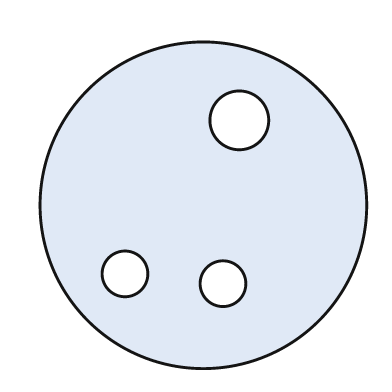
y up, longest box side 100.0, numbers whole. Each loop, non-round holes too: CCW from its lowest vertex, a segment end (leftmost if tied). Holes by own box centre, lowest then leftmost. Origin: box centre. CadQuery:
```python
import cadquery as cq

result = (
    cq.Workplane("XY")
    .moveTo(0.0, 0.0)
    .circle(50.0)
    .moveTo(6.0, -24.0)
    .circle(7.0)
    .moveTo(-24.0, -21.0)
    .circle(7.0)
    .moveTo(11.0, 26.0)
    .circle(9.0)
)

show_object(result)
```